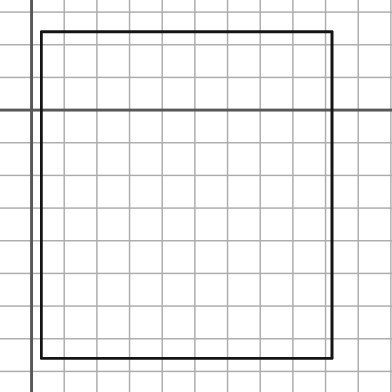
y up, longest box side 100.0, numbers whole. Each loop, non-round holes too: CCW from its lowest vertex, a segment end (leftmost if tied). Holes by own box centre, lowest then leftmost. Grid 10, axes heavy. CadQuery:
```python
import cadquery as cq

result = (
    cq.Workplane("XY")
    .moveTo(3.0, -76.0)
    .lineTo(92.0, -76.0)
    .lineTo(92.0, 24.0)
    .lineTo(3.0, 24.0)
    .close()
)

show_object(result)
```